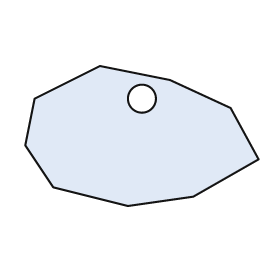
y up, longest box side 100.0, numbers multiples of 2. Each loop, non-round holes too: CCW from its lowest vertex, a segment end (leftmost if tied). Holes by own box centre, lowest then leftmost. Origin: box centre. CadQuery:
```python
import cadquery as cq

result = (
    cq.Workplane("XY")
    .moveTo(-6.0, -30.0)
    .lineTo(22.0, -26.0)
    .lineTo(50.0, -10.0)
    .lineTo(38.0, 12.0)
    .lineTo(12.0, 24.0)
    .lineTo(-18.0, 30.0)
    .lineTo(-46.0, 16.0)
    .lineTo(-50.0, -4.0)
    .lineTo(-38.0, -22.0)
    .close()
    .moveTo(0.0, 16.0)
    .circle(6.0)
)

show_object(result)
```